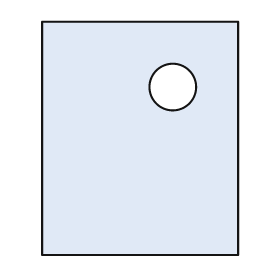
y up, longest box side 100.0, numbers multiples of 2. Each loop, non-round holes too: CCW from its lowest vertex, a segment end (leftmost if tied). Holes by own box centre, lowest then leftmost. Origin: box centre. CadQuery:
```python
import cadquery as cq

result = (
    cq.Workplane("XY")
    .moveTo(-42.0, -50.0)
    .lineTo(42.0, -50.0)
    .lineTo(42.0, 50.0)
    .lineTo(-42.0, 50.0)
    .close()
    .moveTo(14.0, 22.0)
    .circle(10.0)
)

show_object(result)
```